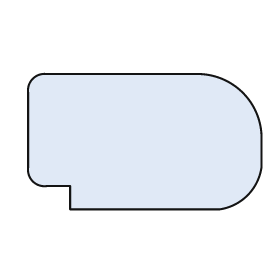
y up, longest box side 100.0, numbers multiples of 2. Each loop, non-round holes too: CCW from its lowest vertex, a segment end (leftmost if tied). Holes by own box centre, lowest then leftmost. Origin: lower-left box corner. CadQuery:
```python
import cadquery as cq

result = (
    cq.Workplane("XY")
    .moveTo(18.0, 0.0)
    .lineTo(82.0, 0.0)
    .threePointArc((94.0, 6.0), (100.0, 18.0))
    .lineTo(100.0, 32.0)
    .threePointArc((92.0, 50.0), (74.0, 58.0))
    .lineTo(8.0, 58.0)
    .threePointArc((2.0, 56.0), (0.0, 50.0))
    .lineTo(0.0, 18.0)
    .threePointArc((2.0, 12.0), (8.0, 10.0))
    .lineTo(18.0, 10.0)
    .close()
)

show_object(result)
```